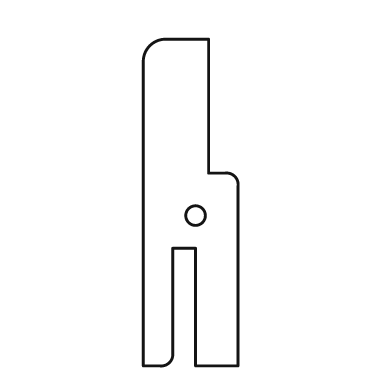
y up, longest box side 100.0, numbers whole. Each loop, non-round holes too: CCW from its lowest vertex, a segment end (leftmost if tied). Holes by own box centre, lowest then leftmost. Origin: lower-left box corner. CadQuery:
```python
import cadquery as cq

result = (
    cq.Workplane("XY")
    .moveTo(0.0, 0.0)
    .lineTo(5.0, 0.0)
    .threePointArc((8.0, 1.0), (9.0, 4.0))
    .lineTo(9.0, 36.0)
    .lineTo(16.0, 36.0)
    .lineTo(16.0, 0.0)
    .lineTo(29.0, 0.0)
    .lineTo(29.0, 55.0)
    .threePointArc((28.0, 58.0), (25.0, 59.0))
    .lineTo(20.0, 59.0)
    .lineTo(20.0, 100.0)
    .lineTo(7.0, 100.0)
    .threePointArc((2.0, 98.0), (0.0, 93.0))
    .close()
    .moveTo(16.0, 46.0)
    .circle(3.0)
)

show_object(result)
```